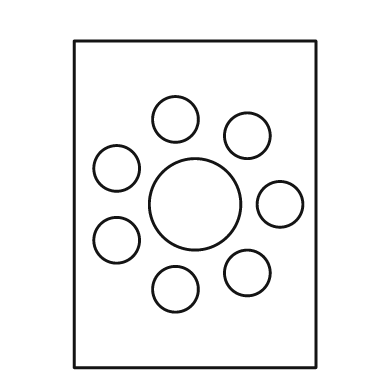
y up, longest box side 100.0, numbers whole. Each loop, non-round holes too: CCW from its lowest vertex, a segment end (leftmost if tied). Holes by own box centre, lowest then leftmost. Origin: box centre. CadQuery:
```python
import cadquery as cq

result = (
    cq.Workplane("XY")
    .moveTo(-37.0, -50.0)
    .lineTo(37.0, -50.0)
    .lineTo(37.0, 50.0)
    .lineTo(-37.0, 50.0)
    .close()
    .moveTo(-6.0, -26.0)
    .circle(7.0)
    .moveTo(16.0, -21.0)
    .circle(7.0)
    .moveTo(-24.0, -11.0)
    .circle(7.0)
    .moveTo(0.0, 0.0)
    .circle(14.0)
    .moveTo(26.0, 0.0)
    .circle(7.0)
    .moveTo(-24.0, 11.0)
    .circle(7.0)
    .moveTo(16.0, 21.0)
    .circle(7.0)
    .moveTo(-6.0, 26.0)
    .circle(7.0)
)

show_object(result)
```